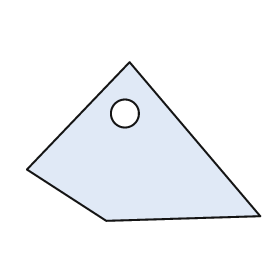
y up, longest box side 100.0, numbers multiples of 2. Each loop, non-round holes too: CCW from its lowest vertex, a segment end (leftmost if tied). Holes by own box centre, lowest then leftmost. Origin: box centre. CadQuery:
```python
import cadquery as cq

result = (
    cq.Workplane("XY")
    .moveTo(-16.0, -34.0)
    .lineTo(50.0, -32.0)
    .lineTo(-6.0, 34.0)
    .lineTo(-50.0, -12.0)
    .close()
    .moveTo(-8.0, 12.0)
    .circle(6.0)
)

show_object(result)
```